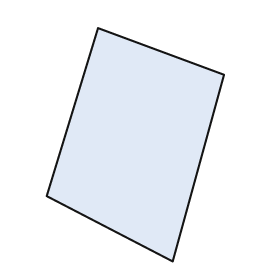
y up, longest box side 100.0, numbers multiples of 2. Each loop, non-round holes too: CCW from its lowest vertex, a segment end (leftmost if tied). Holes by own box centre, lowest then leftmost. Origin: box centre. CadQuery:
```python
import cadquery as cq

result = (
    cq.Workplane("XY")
    .moveTo(16.0, -50.0)
    .lineTo(38.0, 30.0)
    .lineTo(-16.0, 50.0)
    .lineTo(-38.0, -22.0)
    .close()
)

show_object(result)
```